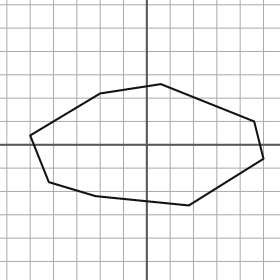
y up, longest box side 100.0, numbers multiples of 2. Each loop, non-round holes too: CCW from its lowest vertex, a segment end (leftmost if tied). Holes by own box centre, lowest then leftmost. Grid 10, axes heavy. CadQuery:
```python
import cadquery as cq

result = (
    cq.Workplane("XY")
    .moveTo(18.0, -26.0)
    .lineTo(50.0, -6.0)
    .lineTo(46.0, 10.0)
    .lineTo(6.0, 26.0)
    .lineTo(-20.0, 22.0)
    .lineTo(-50.0, 4.0)
    .lineTo(-42.0, -16.0)
    .lineTo(-22.0, -22.0)
    .close()
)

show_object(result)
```